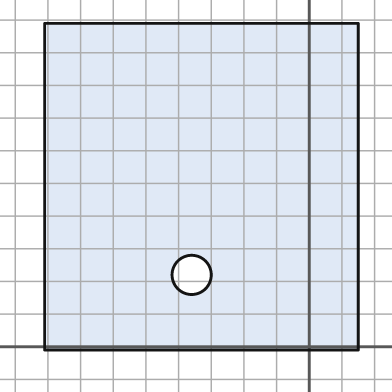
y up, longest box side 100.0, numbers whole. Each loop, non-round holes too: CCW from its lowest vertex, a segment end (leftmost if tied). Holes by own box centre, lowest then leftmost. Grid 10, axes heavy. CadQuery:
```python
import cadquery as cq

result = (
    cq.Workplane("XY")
    .moveTo(-81.0, -1.0)
    .lineTo(15.0, -1.0)
    .lineTo(15.0, 99.0)
    .lineTo(-81.0, 99.0)
    .close()
    .moveTo(-36.0, 22.0)
    .circle(6.0)
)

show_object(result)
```